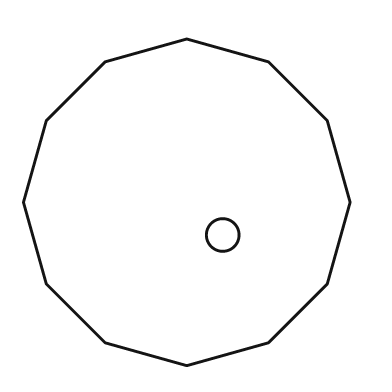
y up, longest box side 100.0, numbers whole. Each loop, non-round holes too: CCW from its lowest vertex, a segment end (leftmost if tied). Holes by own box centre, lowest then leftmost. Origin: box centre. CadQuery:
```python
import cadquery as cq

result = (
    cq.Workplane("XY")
    .moveTo(0.0, -50.0)
    .lineTo(25.0, -43.0)
    .lineTo(43.0, -25.0)
    .lineTo(50.0, 0.0)
    .lineTo(43.0, 25.0)
    .lineTo(25.0, 43.0)
    .lineTo(0.0, 50.0)
    .lineTo(-25.0, 43.0)
    .lineTo(-43.0, 25.0)
    .lineTo(-50.0, 0.0)
    .lineTo(-43.0, -25.0)
    .lineTo(-25.0, -43.0)
    .close()
    .moveTo(11.0, -10.0)
    .circle(5.0)
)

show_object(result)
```